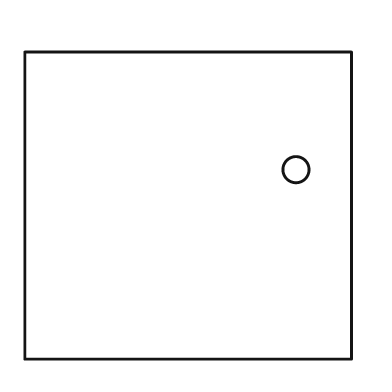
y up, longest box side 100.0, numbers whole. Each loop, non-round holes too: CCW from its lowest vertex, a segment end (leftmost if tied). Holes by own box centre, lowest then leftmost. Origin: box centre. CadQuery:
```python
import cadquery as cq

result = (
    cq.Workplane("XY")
    .moveTo(-50.0, -47.0)
    .lineTo(50.0, -47.0)
    .lineTo(50.0, 47.0)
    .lineTo(-50.0, 47.0)
    .close()
    .moveTo(33.0, 11.0)
    .circle(4.0)
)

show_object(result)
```